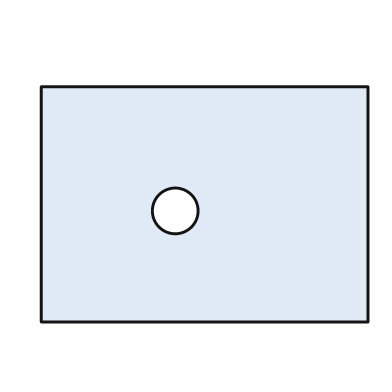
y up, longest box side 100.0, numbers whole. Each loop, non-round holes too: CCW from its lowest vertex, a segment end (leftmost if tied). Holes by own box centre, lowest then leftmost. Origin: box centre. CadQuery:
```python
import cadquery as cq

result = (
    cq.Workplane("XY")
    .moveTo(-50.0, -36.0)
    .lineTo(50.0, -36.0)
    .lineTo(50.0, 36.0)
    .lineTo(-50.0, 36.0)
    .close()
    .moveTo(-9.0, -2.0)
    .circle(7.0)
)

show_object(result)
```